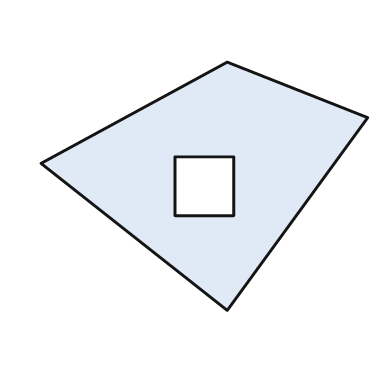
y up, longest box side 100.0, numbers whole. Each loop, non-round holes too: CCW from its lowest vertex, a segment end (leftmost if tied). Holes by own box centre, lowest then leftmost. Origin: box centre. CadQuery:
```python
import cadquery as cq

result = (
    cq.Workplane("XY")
    .moveTo(7.0, -38.0)
    .lineTo(50.0, 21.0)
    .lineTo(7.0, 38.0)
    .lineTo(-50.0, 7.0)
    .close()
    .moveTo(-9.0, -9.0)
    .lineTo(9.0, -9.0)
    .lineTo(9.0, 9.0)
    .lineTo(-9.0, 9.0)
    .close()
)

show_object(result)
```